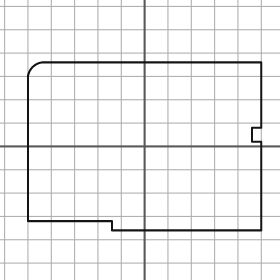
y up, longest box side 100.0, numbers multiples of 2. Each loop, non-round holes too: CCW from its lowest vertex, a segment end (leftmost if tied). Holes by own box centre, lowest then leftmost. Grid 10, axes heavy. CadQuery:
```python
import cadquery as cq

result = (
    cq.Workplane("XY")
    .moveTo(-14.0, -36.0)
    .lineTo(50.0, -36.0)
    .lineTo(50.0, 2.0)
    .lineTo(46.0, 2.0)
    .lineTo(46.0, 8.0)
    .lineTo(50.0, 8.0)
    .lineTo(50.0, 36.0)
    .lineTo(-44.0, 36.0)
    .threePointArc((-48.0, 34.0), (-50.0, 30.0))
    .lineTo(-50.0, -32.0)
    .lineTo(-14.0, -32.0)
    .close()
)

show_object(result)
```